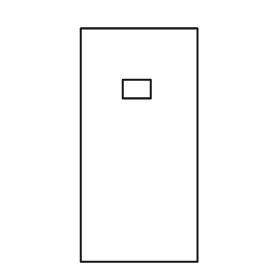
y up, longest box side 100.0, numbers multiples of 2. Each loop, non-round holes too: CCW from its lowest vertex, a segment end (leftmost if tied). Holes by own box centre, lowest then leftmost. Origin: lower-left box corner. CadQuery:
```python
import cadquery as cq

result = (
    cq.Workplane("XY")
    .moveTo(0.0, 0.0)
    .lineTo(50.0, 0.0)
    .lineTo(50.0, 100.0)
    .lineTo(0.0, 100.0)
    .close()
    .moveTo(18.0, 70.0)
    .lineTo(30.0, 70.0)
    .lineTo(30.0, 78.0)
    .lineTo(18.0, 78.0)
    .close()
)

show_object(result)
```